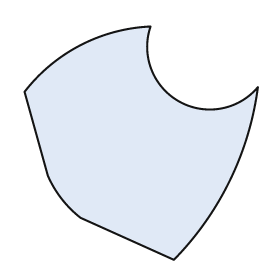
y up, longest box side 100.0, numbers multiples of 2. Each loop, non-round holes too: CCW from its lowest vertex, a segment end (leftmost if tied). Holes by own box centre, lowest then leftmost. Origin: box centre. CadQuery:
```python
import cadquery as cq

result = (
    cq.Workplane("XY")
    .moveTo(14.0, -50.0)
    .threePointArc((38.0, -16.0), (50.0, 24.0))
    .threePointArc((16.0, 18.0), (4.0, 50.0))
    .threePointArc((-26.0, 42.0), (-50.0, 22.0))
    .lineTo(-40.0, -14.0)
    .threePointArc((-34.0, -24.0), (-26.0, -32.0))
    .close()
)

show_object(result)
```